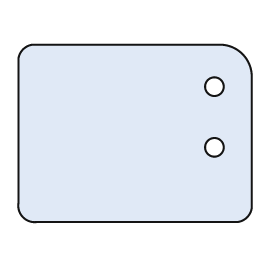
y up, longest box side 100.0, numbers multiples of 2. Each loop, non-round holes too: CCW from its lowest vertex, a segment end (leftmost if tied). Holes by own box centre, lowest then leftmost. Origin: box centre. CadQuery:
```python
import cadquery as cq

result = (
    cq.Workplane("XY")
    .moveTo(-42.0, -38.0)
    .lineTo(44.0, -38.0)
    .threePointArc((48.0, -36.0), (50.0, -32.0))
    .lineTo(50.0, 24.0)
    .threePointArc((46.0, 34.0), (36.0, 38.0))
    .lineTo(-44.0, 38.0)
    .threePointArc((-48.0, 36.0), (-50.0, 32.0))
    .lineTo(-50.0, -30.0)
    .threePointArc((-48.0, -36.0), (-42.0, -38.0))
    .close()
    .moveTo(34.0, -6.0)
    .circle(4.0)
    .moveTo(34.0, 20.0)
    .circle(4.0)
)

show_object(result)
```